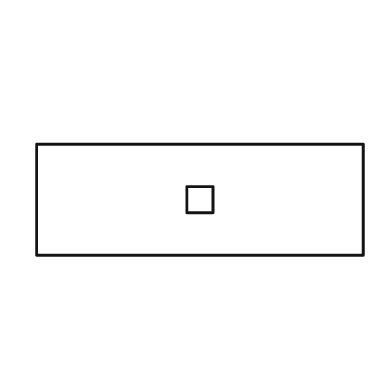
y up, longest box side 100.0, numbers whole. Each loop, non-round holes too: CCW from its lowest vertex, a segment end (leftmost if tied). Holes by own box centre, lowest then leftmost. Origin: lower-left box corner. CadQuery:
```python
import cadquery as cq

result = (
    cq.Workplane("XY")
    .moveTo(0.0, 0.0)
    .lineTo(100.0, 0.0)
    .lineTo(100.0, 34.0)
    .lineTo(0.0, 34.0)
    .close()
    .moveTo(46.0, 13.0)
    .lineTo(54.0, 13.0)
    .lineTo(54.0, 21.0)
    .lineTo(46.0, 21.0)
    .close()
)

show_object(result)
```